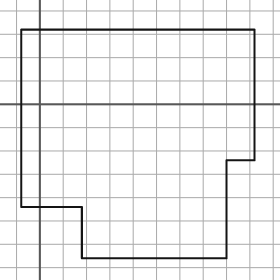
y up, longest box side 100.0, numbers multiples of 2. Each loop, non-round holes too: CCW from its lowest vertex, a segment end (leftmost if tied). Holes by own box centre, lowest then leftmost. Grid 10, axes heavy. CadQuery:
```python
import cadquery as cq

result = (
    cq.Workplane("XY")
    .moveTo(18.0, -66.0)
    .lineTo(80.0, -66.0)
    .lineTo(80.0, -24.0)
    .lineTo(92.0, -24.0)
    .lineTo(92.0, 32.0)
    .lineTo(-8.0, 32.0)
    .lineTo(-8.0, -44.0)
    .lineTo(18.0, -44.0)
    .close()
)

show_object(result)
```